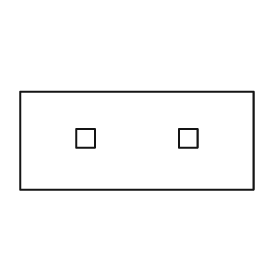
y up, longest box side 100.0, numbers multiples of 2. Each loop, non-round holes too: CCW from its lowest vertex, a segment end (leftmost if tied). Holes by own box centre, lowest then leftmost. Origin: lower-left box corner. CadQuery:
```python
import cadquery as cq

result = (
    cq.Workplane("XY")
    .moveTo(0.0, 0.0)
    .lineTo(100.0, 0.0)
    .lineTo(100.0, 42.0)
    .lineTo(0.0, 42.0)
    .close()
    .moveTo(24.0, 18.0)
    .lineTo(32.0, 18.0)
    .lineTo(32.0, 26.0)
    .lineTo(24.0, 26.0)
    .close()
    .moveTo(68.0, 18.0)
    .lineTo(76.0, 18.0)
    .lineTo(76.0, 26.0)
    .lineTo(68.0, 26.0)
    .close()
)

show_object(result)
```